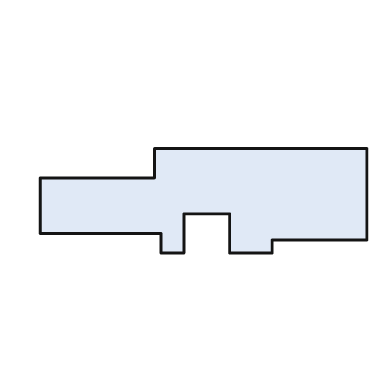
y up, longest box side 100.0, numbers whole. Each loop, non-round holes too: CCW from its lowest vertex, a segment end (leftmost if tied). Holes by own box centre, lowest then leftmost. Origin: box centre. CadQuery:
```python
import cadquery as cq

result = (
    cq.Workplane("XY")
    .moveTo(-13.0, -16.0)
    .lineTo(-6.0, -16.0)
    .lineTo(-6.0, -4.0)
    .lineTo(8.0, -4.0)
    .lineTo(8.0, -16.0)
    .lineTo(21.0, -16.0)
    .lineTo(21.0, -12.0)
    .lineTo(50.0, -12.0)
    .lineTo(50.0, 16.0)
    .lineTo(-15.0, 16.0)
    .lineTo(-15.0, 7.0)
    .lineTo(-50.0, 7.0)
    .lineTo(-50.0, -10.0)
    .lineTo(-13.0, -10.0)
    .close()
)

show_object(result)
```